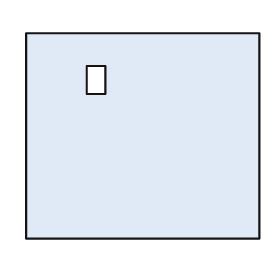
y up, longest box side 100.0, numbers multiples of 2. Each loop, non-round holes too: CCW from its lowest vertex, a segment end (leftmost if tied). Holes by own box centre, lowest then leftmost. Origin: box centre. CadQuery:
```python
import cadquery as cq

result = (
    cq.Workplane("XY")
    .moveTo(-50.0, -44.0)
    .lineTo(50.0, -44.0)
    .lineTo(50.0, 44.0)
    .lineTo(-50.0, 44.0)
    .close()
    .moveTo(-24.0, 18.0)
    .lineTo(-16.0, 18.0)
    .lineTo(-16.0, 30.0)
    .lineTo(-24.0, 30.0)
    .close()
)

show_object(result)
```